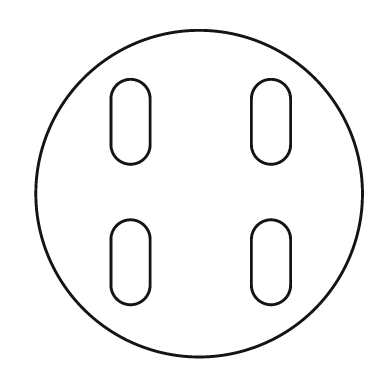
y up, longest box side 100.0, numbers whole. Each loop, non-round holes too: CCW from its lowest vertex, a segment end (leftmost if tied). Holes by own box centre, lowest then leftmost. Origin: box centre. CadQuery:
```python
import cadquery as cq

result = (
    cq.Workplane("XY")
    .moveTo(0.0, 0.0)
    .circle(50.0)
    .moveTo(-27.0, -28.0)
    .threePointArc((-21.0, -34.0), (-15.0, -28.0))
    .lineTo(-15.0, -14.0)
    .threePointArc((-21.0, -8.0), (-27.0, -14.0))
    .close()
    .moveTo(16.0, -28.0)
    .threePointArc((22.0, -34.0), (28.0, -28.0))
    .lineTo(28.0, -14.0)
    .threePointArc((22.0, -8.0), (16.0, -14.0))
    .close()
    .moveTo(-27.0, 15.0)
    .threePointArc((-21.0, 9.0), (-15.0, 15.0))
    .lineTo(-15.0, 29.0)
    .threePointArc((-21.0, 35.0), (-27.0, 29.0))
    .close()
    .moveTo(16.0, 15.0)
    .threePointArc((22.0, 9.0), (28.0, 15.0))
    .lineTo(28.0, 29.0)
    .threePointArc((22.0, 35.0), (16.0, 29.0))
    .close()
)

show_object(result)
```